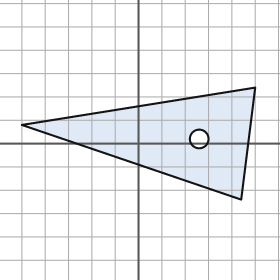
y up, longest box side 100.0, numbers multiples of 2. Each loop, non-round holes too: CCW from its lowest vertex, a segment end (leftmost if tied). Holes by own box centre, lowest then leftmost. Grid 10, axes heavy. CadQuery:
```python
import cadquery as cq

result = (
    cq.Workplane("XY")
    .moveTo(44.0, -24.0)
    .lineTo(50.0, 24.0)
    .lineTo(-50.0, 8.0)
    .close()
    .moveTo(26.0, 2.0)
    .circle(4.0)
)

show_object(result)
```